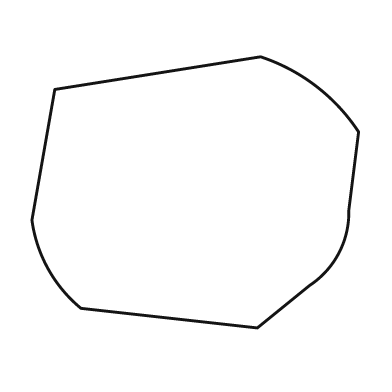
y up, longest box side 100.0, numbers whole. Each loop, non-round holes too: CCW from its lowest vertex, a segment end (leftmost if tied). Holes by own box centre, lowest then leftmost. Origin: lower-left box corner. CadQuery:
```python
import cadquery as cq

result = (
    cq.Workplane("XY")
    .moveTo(69.0, 0.0)
    .lineTo(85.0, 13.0)
    .threePointArc((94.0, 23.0), (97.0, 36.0))
    .lineTo(100.0, 60.0)
    .threePointArc((87.0, 74.0), (70.0, 83.0))
    .lineTo(7.0, 73.0)
    .lineTo(0.0, 33.0)
    .threePointArc((5.0, 18.0), (15.0, 6.0))
    .close()
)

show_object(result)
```